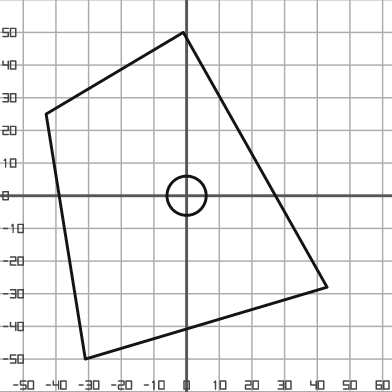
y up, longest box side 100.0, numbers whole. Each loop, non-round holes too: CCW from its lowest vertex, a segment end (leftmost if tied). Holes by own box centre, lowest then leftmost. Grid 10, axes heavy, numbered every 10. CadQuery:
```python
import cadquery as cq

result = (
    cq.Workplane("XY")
    .moveTo(-31.0, -50.0)
    .lineTo(43.0, -28.0)
    .lineTo(-1.0, 50.0)
    .lineTo(-43.0, 25.0)
    .close()
    .moveTo(0.0, 0.0)
    .circle(6.0)
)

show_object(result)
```